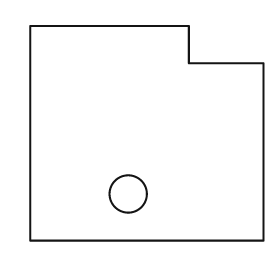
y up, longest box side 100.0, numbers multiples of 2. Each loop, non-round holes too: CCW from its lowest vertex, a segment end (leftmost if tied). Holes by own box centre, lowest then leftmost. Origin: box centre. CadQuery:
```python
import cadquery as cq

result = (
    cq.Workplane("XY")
    .moveTo(-50.0, -46.0)
    .lineTo(50.0, -46.0)
    .lineTo(50.0, 30.0)
    .lineTo(18.0, 30.0)
    .lineTo(18.0, 46.0)
    .lineTo(-50.0, 46.0)
    .close()
    .moveTo(-8.0, -26.0)
    .circle(8.0)
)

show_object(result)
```